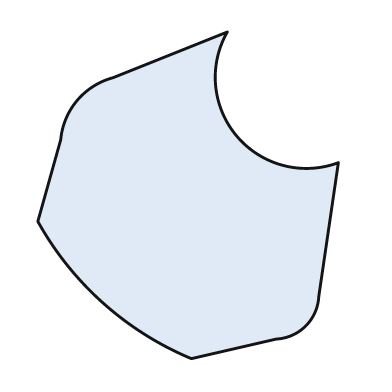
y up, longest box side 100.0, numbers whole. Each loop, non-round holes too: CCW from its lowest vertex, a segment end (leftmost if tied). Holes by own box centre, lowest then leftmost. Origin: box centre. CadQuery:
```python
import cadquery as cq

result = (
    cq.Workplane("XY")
    .moveTo(1.0, -50.0)
    .lineTo(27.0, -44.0)
    .threePointArc((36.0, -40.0), (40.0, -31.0))
    .lineTo(46.0, 10.0)
    .threePointArc((15.0, 18.0), (12.0, 50.0))
    .lineTo(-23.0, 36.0)
    .threePointArc((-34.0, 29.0), (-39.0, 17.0))
    .lineTo(-46.0, -8.0)
    .threePointArc((-26.0, -33.0), (1.0, -50.0))
    .close()
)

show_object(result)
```